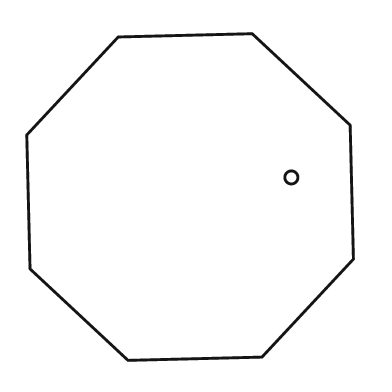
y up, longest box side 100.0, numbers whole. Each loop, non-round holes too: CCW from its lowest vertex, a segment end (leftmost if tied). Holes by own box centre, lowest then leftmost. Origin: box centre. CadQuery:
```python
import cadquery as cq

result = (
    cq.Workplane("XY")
    .moveTo(-19.0, -50.0)
    .lineTo(22.0, -49.0)
    .lineTo(50.0, -19.0)
    .lineTo(49.0, 22.0)
    .lineTo(19.0, 50.0)
    .lineTo(-22.0, 49.0)
    .lineTo(-50.0, 19.0)
    .lineTo(-49.0, -22.0)
    .close()
    .moveTo(31.0, 6.0)
    .circle(2.0)
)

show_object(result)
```